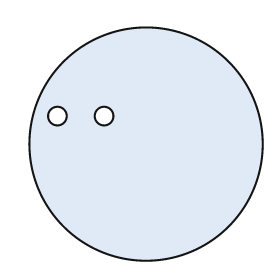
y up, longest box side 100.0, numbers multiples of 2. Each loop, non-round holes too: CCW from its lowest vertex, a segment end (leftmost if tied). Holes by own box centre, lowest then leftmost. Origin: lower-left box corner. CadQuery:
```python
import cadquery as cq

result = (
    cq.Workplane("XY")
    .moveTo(50.0, 50.0)
    .circle(50.0)
    .moveTo(12.0, 62.0)
    .circle(4.0)
    .moveTo(32.0, 62.0)
    .circle(4.0)
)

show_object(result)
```